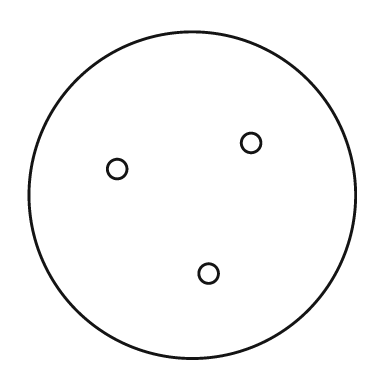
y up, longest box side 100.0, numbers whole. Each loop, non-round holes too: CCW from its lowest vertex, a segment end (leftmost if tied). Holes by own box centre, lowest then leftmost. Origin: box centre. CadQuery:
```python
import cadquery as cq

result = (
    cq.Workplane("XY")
    .moveTo(0.0, 0.0)
    .circle(50.0)
    .moveTo(5.0, -24.0)
    .circle(3.0)
    .moveTo(-23.0, 8.0)
    .circle(3.0)
    .moveTo(18.0, 16.0)
    .circle(3.0)
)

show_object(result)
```